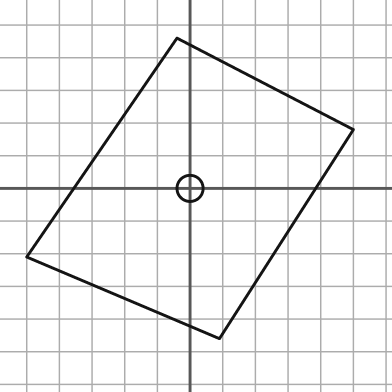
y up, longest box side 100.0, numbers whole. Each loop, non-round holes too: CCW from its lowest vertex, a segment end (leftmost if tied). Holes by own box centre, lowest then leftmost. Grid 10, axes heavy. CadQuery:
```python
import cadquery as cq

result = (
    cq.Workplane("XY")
    .moveTo(9.0, -46.0)
    .lineTo(50.0, 18.0)
    .lineTo(-4.0, 46.0)
    .lineTo(-50.0, -21.0)
    .close()
    .moveTo(0.0, 0.0)
    .circle(4.0)
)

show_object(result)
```